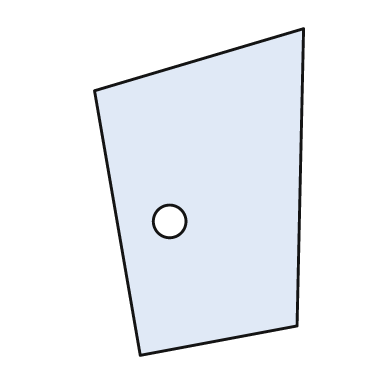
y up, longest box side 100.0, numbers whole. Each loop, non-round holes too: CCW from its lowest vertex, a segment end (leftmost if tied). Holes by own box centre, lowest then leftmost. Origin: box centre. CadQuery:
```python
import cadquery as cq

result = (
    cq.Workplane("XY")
    .moveTo(-18.0, -50.0)
    .lineTo(30.0, -41.0)
    .lineTo(32.0, 50.0)
    .lineTo(-32.0, 31.0)
    .close()
    .moveTo(-9.0, -9.0)
    .circle(5.0)
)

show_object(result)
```